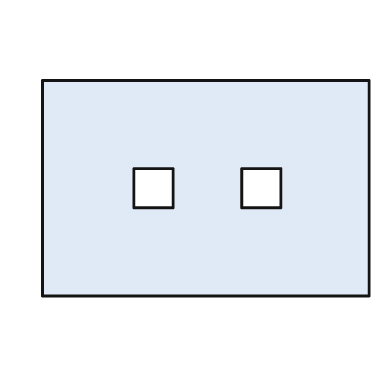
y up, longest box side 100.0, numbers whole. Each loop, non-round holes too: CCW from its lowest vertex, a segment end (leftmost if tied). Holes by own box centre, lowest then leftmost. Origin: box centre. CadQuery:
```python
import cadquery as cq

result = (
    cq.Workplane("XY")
    .moveTo(-50.0, -33.0)
    .lineTo(50.0, -33.0)
    .lineTo(50.0, 33.0)
    .lineTo(-50.0, 33.0)
    .close()
    .moveTo(-22.0, -6.0)
    .lineTo(-10.0, -6.0)
    .lineTo(-10.0, 6.0)
    .lineTo(-22.0, 6.0)
    .close()
    .moveTo(11.0, -6.0)
    .lineTo(23.0, -6.0)
    .lineTo(23.0, 6.0)
    .lineTo(11.0, 6.0)
    .close()
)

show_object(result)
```